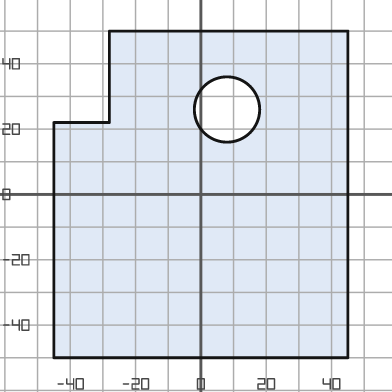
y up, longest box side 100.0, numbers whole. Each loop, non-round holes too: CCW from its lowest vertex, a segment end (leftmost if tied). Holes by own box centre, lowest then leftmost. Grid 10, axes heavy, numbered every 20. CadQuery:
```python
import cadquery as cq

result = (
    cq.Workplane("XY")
    .moveTo(-45.0, -50.0)
    .lineTo(45.0, -50.0)
    .lineTo(45.0, 50.0)
    .lineTo(-28.0, 50.0)
    .lineTo(-28.0, 22.0)
    .lineTo(-45.0, 22.0)
    .close()
    .moveTo(8.0, 26.0)
    .circle(10.0)
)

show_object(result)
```